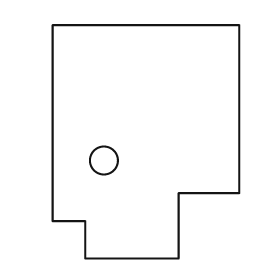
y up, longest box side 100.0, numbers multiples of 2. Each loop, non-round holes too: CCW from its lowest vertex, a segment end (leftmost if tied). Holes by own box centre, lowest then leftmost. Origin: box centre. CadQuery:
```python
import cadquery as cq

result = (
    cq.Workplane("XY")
    .moveTo(-26.0, -50.0)
    .lineTo(14.0, -50.0)
    .lineTo(14.0, -22.0)
    .lineTo(40.0, -22.0)
    .lineTo(40.0, 50.0)
    .lineTo(-40.0, 50.0)
    .lineTo(-40.0, -34.0)
    .lineTo(-26.0, -34.0)
    .close()
    .moveTo(-18.0, -8.0)
    .circle(6.0)
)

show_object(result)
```